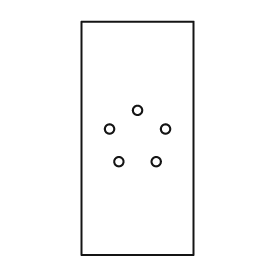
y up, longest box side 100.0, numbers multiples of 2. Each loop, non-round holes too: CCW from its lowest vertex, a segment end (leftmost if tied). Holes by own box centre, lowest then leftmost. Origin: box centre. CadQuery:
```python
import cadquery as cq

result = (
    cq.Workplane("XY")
    .moveTo(-24.0, -50.0)
    .lineTo(24.0, -50.0)
    .lineTo(24.0, 50.0)
    .lineTo(-24.0, 50.0)
    .close()
    .moveTo(-8.0, -10.0)
    .circle(2.0)
    .moveTo(8.0, -10.0)
    .circle(2.0)
    .moveTo(-12.0, 4.0)
    .circle(2.0)
    .moveTo(12.0, 4.0)
    .circle(2.0)
    .moveTo(0.0, 12.0)
    .circle(2.0)
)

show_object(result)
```